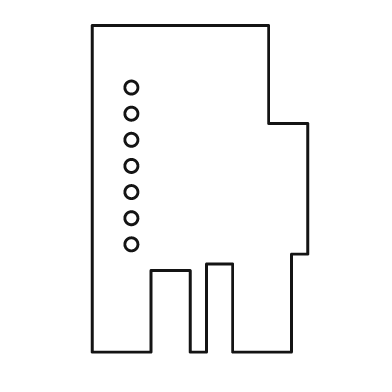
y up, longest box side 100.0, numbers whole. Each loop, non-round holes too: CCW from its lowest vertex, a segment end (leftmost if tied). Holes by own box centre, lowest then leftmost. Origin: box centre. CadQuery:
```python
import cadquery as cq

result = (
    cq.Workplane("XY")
    .moveTo(-33.0, -50.0)
    .lineTo(-15.0, -50.0)
    .lineTo(-15.0, -25.0)
    .lineTo(-3.0, -25.0)
    .lineTo(-3.0, -50.0)
    .lineTo(2.0, -50.0)
    .lineTo(2.0, -23.0)
    .lineTo(10.0, -23.0)
    .lineTo(10.0, -50.0)
    .lineTo(28.0, -50.0)
    .lineTo(28.0, -20.0)
    .lineTo(33.0, -20.0)
    .lineTo(33.0, 20.0)
    .lineTo(21.0, 20.0)
    .lineTo(21.0, 50.0)
    .lineTo(-33.0, 50.0)
    .close()
    .moveTo(-21.0, -17.0)
    .circle(2.0)
    .moveTo(-21.0, -9.0)
    .circle(2.0)
    .moveTo(-21.0, -1.0)
    .circle(2.0)
    .moveTo(-21.0, 7.0)
    .circle(2.0)
    .moveTo(-21.0, 15.0)
    .circle(2.0)
    .moveTo(-21.0, 23.0)
    .circle(2.0)
    .moveTo(-21.0, 31.0)
    .circle(2.0)
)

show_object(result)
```